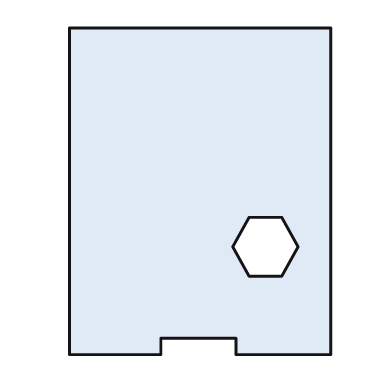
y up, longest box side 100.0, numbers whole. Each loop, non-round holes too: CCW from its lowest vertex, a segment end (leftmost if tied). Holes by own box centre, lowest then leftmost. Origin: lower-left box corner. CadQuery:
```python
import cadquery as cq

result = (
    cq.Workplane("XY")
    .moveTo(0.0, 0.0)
    .lineTo(28.0, 0.0)
    .lineTo(28.0, 5.0)
    .lineTo(51.0, 5.0)
    .lineTo(51.0, 0.0)
    .lineTo(80.0, 0.0)
    .lineTo(80.0, 100.0)
    .lineTo(0.0, 100.0)
    .close()
    .moveTo(55.0, 24.0)
    .lineTo(65.0, 24.0)
    .lineTo(70.0, 33.0)
    .lineTo(65.0, 42.0)
    .lineTo(55.0, 42.0)
    .lineTo(50.0, 33.0)
    .close()
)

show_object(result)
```